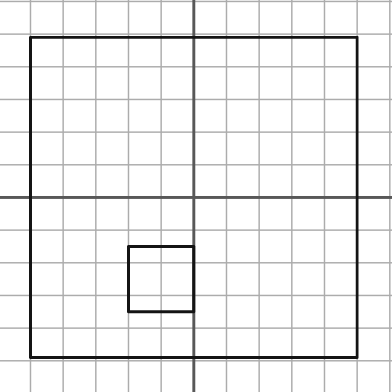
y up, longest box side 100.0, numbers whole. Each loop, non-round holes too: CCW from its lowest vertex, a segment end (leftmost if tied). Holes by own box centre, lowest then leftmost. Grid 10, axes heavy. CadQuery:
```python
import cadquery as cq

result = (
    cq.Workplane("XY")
    .moveTo(-50.0, -49.0)
    .lineTo(50.0, -49.0)
    .lineTo(50.0, 49.0)
    .lineTo(-50.0, 49.0)
    .close()
    .moveTo(-20.0, -35.0)
    .lineTo(0.0, -35.0)
    .lineTo(0.0, -15.0)
    .lineTo(-20.0, -15.0)
    .close()
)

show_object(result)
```